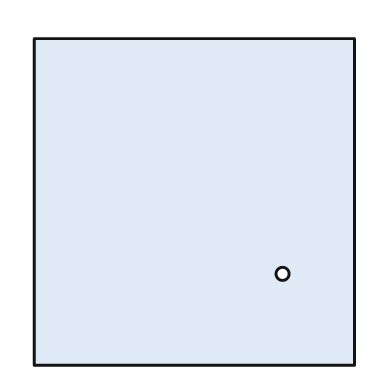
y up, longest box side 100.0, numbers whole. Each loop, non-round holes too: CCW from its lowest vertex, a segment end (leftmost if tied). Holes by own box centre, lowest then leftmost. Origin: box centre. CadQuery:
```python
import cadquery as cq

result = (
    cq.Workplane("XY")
    .moveTo(-49.0, -50.0)
    .lineTo(49.0, -50.0)
    .lineTo(49.0, 50.0)
    .lineTo(-49.0, 50.0)
    .close()
    .moveTo(27.0, -22.0)
    .circle(2.0)
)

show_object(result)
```